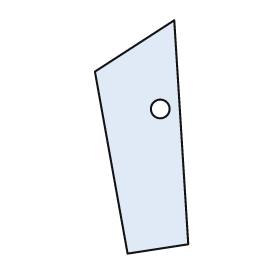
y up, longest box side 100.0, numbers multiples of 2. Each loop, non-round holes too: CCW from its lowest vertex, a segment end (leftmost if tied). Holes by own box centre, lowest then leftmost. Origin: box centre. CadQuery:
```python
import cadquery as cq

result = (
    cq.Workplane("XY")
    .moveTo(-6.0, -50.0)
    .lineTo(20.0, -46.0)
    .lineTo(14.0, 50.0)
    .lineTo(-20.0, 28.0)
    .close()
    .moveTo(8.0, 12.0)
    .circle(4.0)
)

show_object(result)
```